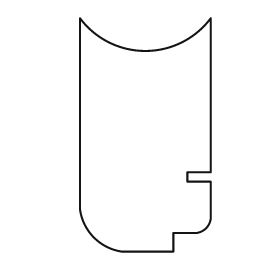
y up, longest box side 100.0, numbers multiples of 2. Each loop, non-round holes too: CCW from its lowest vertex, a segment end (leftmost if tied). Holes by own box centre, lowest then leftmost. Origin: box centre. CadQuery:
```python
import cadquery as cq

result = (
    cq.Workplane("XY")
    .moveTo(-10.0, -50.0)
    .lineTo(12.0, -50.0)
    .lineTo(12.0, -42.0)
    .lineTo(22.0, -42.0)
    .threePointArc((26.0, -40.0), (28.0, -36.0))
    .lineTo(28.0, -20.0)
    .lineTo(18.0, -20.0)
    .lineTo(18.0, -16.0)
    .lineTo(28.0, -16.0)
    .lineTo(28.0, 50.0)
    .threePointArc((0.0, 36.0), (-28.0, 50.0))
    .lineTo(-28.0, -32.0)
    .threePointArc((-22.0, -44.0), (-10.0, -50.0))
    .close()
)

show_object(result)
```